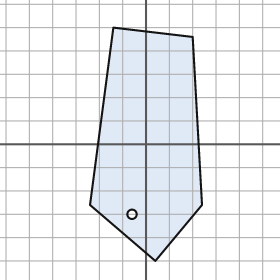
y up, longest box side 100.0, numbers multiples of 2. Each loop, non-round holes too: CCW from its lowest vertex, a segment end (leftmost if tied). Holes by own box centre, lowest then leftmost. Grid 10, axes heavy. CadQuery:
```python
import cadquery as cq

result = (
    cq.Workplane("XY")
    .moveTo(4.0, -50.0)
    .lineTo(24.0, -26.0)
    .lineTo(20.0, 46.0)
    .lineTo(-14.0, 50.0)
    .lineTo(-24.0, -26.0)
    .close()
    .moveTo(-6.0, -30.0)
    .circle(2.0)
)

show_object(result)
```